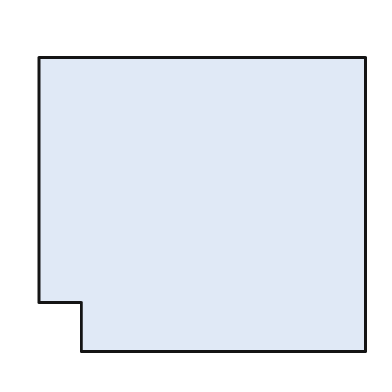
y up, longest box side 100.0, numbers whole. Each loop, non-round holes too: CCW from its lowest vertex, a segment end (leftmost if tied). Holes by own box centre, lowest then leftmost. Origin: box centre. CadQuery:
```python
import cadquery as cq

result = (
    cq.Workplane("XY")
    .moveTo(-37.0, -45.0)
    .lineTo(50.0, -45.0)
    .lineTo(50.0, 45.0)
    .lineTo(-50.0, 45.0)
    .lineTo(-50.0, -30.0)
    .lineTo(-37.0, -30.0)
    .close()
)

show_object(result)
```